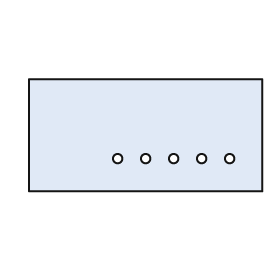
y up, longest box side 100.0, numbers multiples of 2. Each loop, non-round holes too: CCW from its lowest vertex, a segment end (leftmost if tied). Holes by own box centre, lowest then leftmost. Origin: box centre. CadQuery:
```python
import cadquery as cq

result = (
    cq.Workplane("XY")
    .moveTo(-50.0, -24.0)
    .lineTo(50.0, -24.0)
    .lineTo(50.0, 24.0)
    .lineTo(-50.0, 24.0)
    .close()
    .moveTo(-12.0, -10.0)
    .circle(2.0)
    .moveTo(0.0, -10.0)
    .circle(2.0)
    .moveTo(12.0, -10.0)
    .circle(2.0)
    .moveTo(24.0, -10.0)
    .circle(2.0)
    .moveTo(36.0, -10.0)
    .circle(2.0)
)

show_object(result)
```